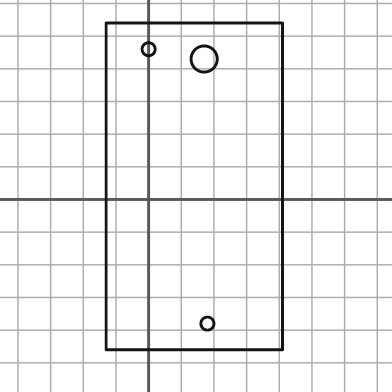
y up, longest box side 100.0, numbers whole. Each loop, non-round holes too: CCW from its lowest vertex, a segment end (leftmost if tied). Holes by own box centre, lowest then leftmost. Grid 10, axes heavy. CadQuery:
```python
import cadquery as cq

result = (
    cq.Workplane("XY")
    .moveTo(-13.0, -46.0)
    .lineTo(41.0, -46.0)
    .lineTo(41.0, 54.0)
    .lineTo(-13.0, 54.0)
    .close()
    .moveTo(18.0, -38.0)
    .circle(2.0)
    .moveTo(17.0, 43.0)
    .circle(4.0)
    .moveTo(0.0, 46.0)
    .circle(2.0)
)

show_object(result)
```